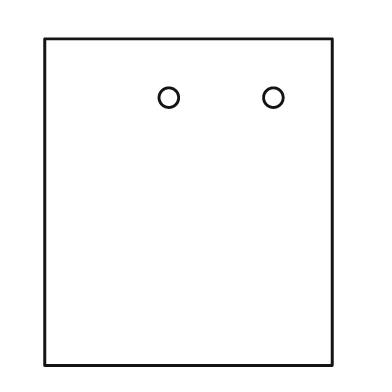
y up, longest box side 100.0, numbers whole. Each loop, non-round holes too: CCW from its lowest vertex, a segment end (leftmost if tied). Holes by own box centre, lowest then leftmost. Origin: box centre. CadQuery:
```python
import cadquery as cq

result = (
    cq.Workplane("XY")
    .moveTo(-44.0, -50.0)
    .lineTo(44.0, -50.0)
    .lineTo(44.0, 50.0)
    .lineTo(-44.0, 50.0)
    .close()
    .moveTo(-6.0, 32.0)
    .circle(3.0)
    .moveTo(26.0, 32.0)
    .circle(3.0)
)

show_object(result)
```